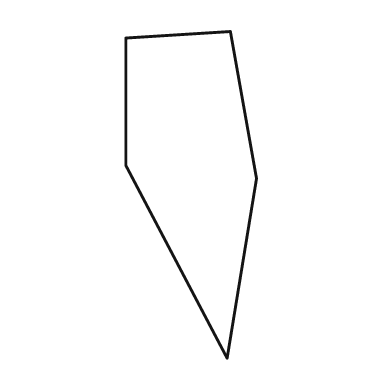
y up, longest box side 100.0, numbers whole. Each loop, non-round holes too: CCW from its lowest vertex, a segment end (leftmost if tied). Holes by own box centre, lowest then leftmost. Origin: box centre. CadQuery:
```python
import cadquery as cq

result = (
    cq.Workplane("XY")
    .moveTo(11.0, -50.0)
    .lineTo(20.0, 5.0)
    .lineTo(12.0, 50.0)
    .lineTo(-20.0, 48.0)
    .lineTo(-20.0, 9.0)
    .close()
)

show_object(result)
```